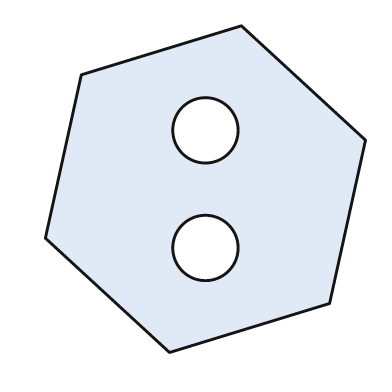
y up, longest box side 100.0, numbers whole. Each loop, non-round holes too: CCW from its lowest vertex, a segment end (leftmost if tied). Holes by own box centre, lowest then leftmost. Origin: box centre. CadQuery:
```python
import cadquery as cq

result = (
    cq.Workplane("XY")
    .moveTo(-11.0, -50.0)
    .lineTo(38.0, -35.0)
    .lineTo(49.0, 15.0)
    .lineTo(11.0, 50.0)
    .lineTo(-38.0, 35.0)
    .lineTo(-49.0, -15.0)
    .close()
    .moveTo(0.0, -18.0)
    .circle(10.0)
    .moveTo(0.0, 18.0)
    .circle(10.0)
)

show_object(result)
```